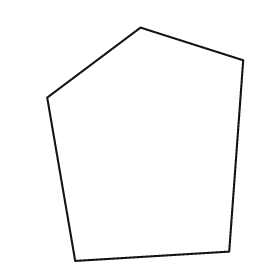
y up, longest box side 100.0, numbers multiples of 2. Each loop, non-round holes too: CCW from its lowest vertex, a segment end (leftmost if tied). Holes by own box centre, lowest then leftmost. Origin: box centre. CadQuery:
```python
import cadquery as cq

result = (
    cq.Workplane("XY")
    .moveTo(-30.0, -50.0)
    .lineTo(36.0, -46.0)
    .lineTo(42.0, 36.0)
    .lineTo(-2.0, 50.0)
    .lineTo(-42.0, 20.0)
    .close()
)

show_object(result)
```